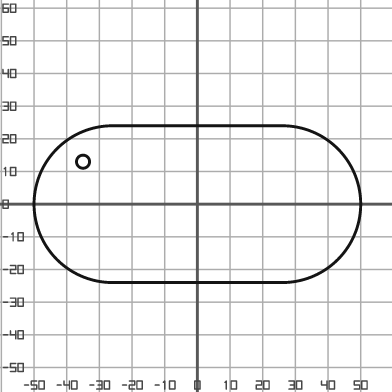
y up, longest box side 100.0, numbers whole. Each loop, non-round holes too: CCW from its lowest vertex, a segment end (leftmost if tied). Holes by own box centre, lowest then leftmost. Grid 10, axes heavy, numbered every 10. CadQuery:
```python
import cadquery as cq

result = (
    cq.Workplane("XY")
    .moveTo(-26.0, -24.0)
    .lineTo(26.0, -24.0)
    .threePointArc((50.0, 0.0), (26.0, 24.0))
    .lineTo(-26.0, 24.0)
    .threePointArc((-50.0, 0.0), (-26.0, -24.0))
    .close()
    .moveTo(-35.0, 13.0)
    .circle(2.0)
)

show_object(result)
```